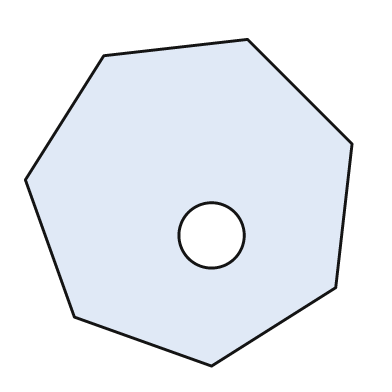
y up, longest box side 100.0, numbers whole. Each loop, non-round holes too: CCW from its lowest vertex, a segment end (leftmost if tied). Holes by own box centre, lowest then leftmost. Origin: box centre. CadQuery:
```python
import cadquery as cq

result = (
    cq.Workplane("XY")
    .moveTo(7.0, -50.0)
    .lineTo(45.0, -26.0)
    .lineTo(50.0, 18.0)
    .lineTo(18.0, 50.0)
    .lineTo(-26.0, 45.0)
    .lineTo(-50.0, 7.0)
    .lineTo(-35.0, -35.0)
    .close()
    .moveTo(7.0, -10.0)
    .circle(10.0)
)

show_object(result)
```